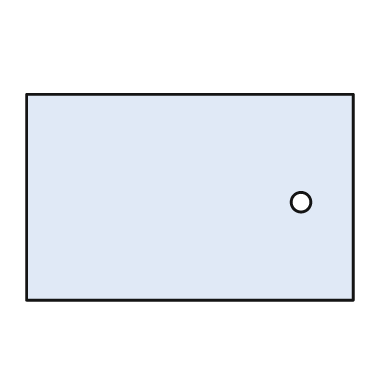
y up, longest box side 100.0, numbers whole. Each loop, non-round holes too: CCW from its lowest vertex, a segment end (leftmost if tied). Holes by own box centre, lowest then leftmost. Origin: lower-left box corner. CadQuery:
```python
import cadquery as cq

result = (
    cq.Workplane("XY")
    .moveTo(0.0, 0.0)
    .lineTo(100.0, 0.0)
    .lineTo(100.0, 63.0)
    .lineTo(0.0, 63.0)
    .close()
    .moveTo(84.0, 30.0)
    .circle(3.0)
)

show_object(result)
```